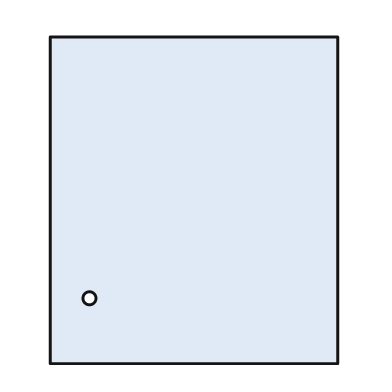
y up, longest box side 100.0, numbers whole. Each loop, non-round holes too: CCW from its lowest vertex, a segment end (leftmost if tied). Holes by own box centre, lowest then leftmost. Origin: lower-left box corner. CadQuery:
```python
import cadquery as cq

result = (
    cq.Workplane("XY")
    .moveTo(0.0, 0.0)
    .lineTo(88.0, 0.0)
    .lineTo(88.0, 100.0)
    .lineTo(0.0, 100.0)
    .close()
    .moveTo(12.0, 20.0)
    .circle(2.0)
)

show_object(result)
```